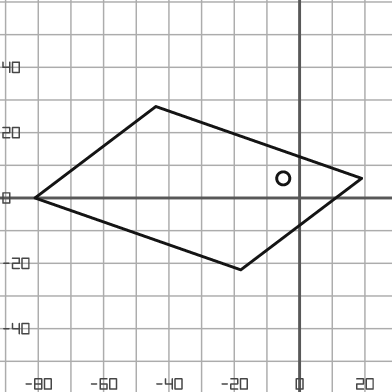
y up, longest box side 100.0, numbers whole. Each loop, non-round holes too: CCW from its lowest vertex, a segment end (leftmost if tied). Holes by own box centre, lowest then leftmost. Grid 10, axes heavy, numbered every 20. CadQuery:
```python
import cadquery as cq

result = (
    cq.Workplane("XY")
    .moveTo(-18.0, -22.0)
    .lineTo(19.0, 6.0)
    .lineTo(-44.0, 28.0)
    .lineTo(-81.0, 0.0)
    .close()
    .moveTo(-5.0, 6.0)
    .circle(2.0)
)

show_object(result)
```